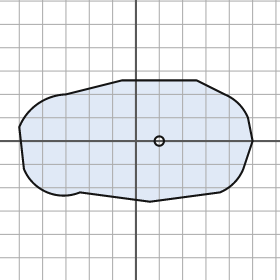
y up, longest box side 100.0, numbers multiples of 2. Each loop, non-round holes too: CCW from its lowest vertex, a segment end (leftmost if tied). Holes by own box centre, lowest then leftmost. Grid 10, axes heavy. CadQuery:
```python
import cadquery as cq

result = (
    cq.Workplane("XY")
    .moveTo(6.0, -26.0)
    .lineTo(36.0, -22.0)
    .threePointArc((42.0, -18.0), (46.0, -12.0))
    .lineTo(50.0, 0.0)
    .lineTo(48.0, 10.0)
    .threePointArc((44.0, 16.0), (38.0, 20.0))
    .lineTo(26.0, 26.0)
    .lineTo(-6.0, 26.0)
    .lineTo(-30.0, 20.0)
    .threePointArc((-42.0, 16.0), (-50.0, 6.0))
    .lineTo(-48.0, -12.0)
    .threePointArc((-38.0, -22.0), (-24.0, -22.0))
    .close()
    .moveTo(10.0, 0.0)
    .circle(2.0)
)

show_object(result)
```